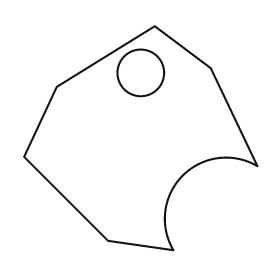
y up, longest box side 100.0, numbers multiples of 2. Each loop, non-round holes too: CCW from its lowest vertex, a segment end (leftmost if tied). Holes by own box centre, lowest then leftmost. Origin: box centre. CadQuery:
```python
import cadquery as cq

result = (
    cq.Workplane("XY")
    .moveTo(14.0, -48.0)
    .threePointArc((18.0, -16.0), (50.0, -12.0))
    .lineTo(30.0, 30.0)
    .lineTo(6.0, 48.0)
    .lineTo(-36.0, 22.0)
    .lineTo(-50.0, -8.0)
    .lineTo(-14.0, -44.0)
    .close()
    .moveTo(0.0, 28.0)
    .circle(10.0)
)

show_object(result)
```